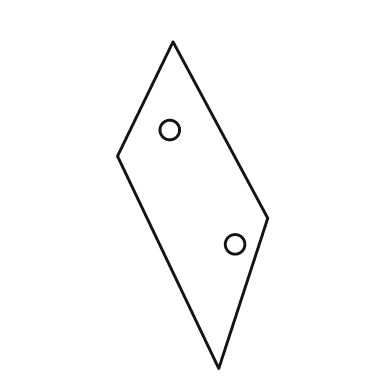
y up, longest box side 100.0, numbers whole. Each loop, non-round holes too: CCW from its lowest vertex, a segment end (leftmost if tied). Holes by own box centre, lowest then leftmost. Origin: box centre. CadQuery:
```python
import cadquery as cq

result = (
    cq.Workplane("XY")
    .moveTo(8.0, -50.0)
    .lineTo(23.0, -4.0)
    .lineTo(-6.0, 50.0)
    .lineTo(-23.0, 15.0)
    .close()
    .moveTo(13.0, -12.0)
    .circle(3.0)
    .moveTo(-7.0, 23.0)
    .circle(3.0)
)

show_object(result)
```